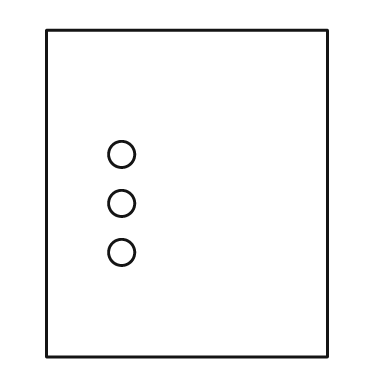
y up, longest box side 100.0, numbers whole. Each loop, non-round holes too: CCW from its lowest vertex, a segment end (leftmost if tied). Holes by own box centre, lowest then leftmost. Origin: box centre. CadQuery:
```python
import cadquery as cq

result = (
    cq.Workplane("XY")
    .moveTo(-43.0, -50.0)
    .lineTo(43.0, -50.0)
    .lineTo(43.0, 50.0)
    .lineTo(-43.0, 50.0)
    .close()
    .moveTo(-20.0, -18.0)
    .circle(4.0)
    .moveTo(-20.0, -3.0)
    .circle(4.0)
    .moveTo(-20.0, 12.0)
    .circle(4.0)
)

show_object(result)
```